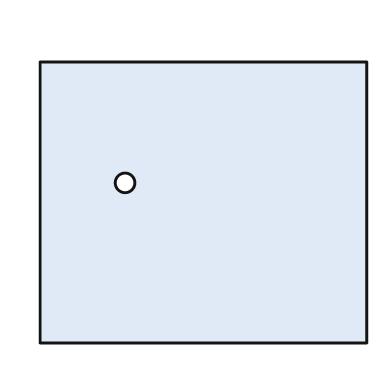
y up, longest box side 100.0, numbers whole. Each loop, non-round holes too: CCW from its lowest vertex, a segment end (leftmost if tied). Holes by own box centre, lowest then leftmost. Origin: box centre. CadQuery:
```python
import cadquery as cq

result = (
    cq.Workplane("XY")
    .moveTo(-50.0, -43.0)
    .lineTo(50.0, -43.0)
    .lineTo(50.0, 43.0)
    .lineTo(-50.0, 43.0)
    .close()
    .moveTo(-24.0, 6.0)
    .circle(3.0)
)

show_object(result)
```